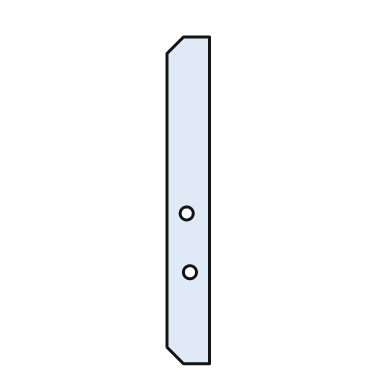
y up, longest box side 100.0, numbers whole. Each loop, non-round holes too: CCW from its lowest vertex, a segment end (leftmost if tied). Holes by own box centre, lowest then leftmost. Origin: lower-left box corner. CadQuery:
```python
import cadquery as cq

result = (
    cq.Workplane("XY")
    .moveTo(5.0, 0.0)
    .lineTo(13.0, 0.0)
    .lineTo(13.0, 100.0)
    .lineTo(5.0, 100.0)
    .lineTo(0.0, 95.0)
    .lineTo(0.0, 5.0)
    .close()
    .moveTo(7.0, 28.0)
    .circle(2.0)
    .moveTo(6.0, 46.0)
    .circle(2.0)
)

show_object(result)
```